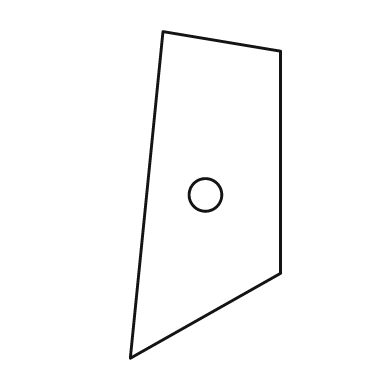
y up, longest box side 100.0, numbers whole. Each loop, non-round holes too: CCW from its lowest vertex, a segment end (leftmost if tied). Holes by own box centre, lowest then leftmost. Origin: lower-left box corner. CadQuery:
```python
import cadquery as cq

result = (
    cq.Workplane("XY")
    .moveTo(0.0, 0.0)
    .lineTo(46.0, 26.0)
    .lineTo(46.0, 94.0)
    .lineTo(10.0, 100.0)
    .close()
    .moveTo(23.0, 50.0)
    .circle(5.0)
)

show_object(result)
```